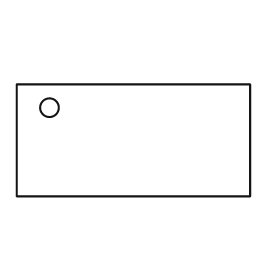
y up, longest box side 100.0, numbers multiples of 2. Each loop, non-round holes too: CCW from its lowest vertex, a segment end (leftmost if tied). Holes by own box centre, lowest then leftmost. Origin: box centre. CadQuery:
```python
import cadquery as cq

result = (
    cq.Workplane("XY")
    .moveTo(-50.0, -24.0)
    .lineTo(50.0, -24.0)
    .lineTo(50.0, 24.0)
    .lineTo(-50.0, 24.0)
    .close()
    .moveTo(-36.0, 14.0)
    .circle(4.0)
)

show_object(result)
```